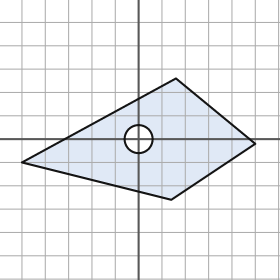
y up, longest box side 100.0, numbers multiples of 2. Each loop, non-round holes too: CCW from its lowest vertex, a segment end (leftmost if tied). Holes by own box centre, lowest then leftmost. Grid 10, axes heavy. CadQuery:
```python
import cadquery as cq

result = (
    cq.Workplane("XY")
    .moveTo(14.0, -26.0)
    .lineTo(50.0, -2.0)
    .lineTo(16.0, 26.0)
    .lineTo(-50.0, -10.0)
    .close()
    .moveTo(0.0, 0.0)
    .circle(6.0)
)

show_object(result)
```